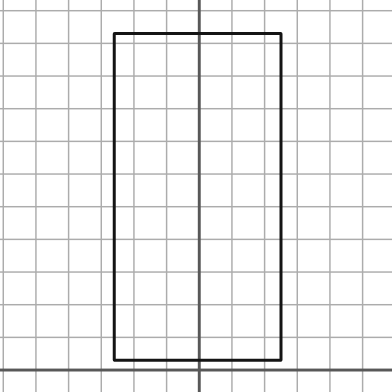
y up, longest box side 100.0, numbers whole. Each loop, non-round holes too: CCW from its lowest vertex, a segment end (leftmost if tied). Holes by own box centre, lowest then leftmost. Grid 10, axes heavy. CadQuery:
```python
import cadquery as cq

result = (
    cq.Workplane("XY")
    .moveTo(-26.0, 3.0)
    .lineTo(25.0, 3.0)
    .lineTo(25.0, 103.0)
    .lineTo(-26.0, 103.0)
    .close()
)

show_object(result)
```